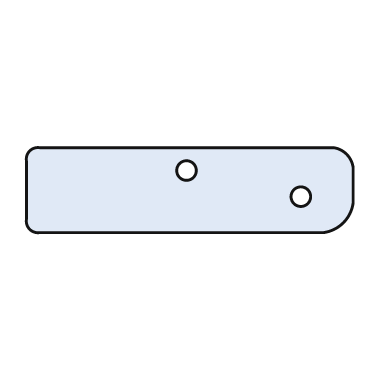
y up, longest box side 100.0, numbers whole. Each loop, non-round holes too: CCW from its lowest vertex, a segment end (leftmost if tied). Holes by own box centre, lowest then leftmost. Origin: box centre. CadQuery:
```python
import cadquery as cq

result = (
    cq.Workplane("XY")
    .moveTo(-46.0, -13.0)
    .lineTo(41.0, -13.0)
    .threePointArc((47.0, -10.0), (50.0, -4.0))
    .lineTo(50.0, 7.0)
    .threePointArc((48.0, 11.0), (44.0, 13.0))
    .lineTo(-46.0, 13.0)
    .threePointArc((-49.0, 12.0), (-50.0, 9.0))
    .lineTo(-50.0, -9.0)
    .threePointArc((-49.0, -12.0), (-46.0, -13.0))
    .close()
    .moveTo(34.0, -2.0)
    .circle(3.0)
    .moveTo(-1.0, 6.0)
    .circle(3.0)
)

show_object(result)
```